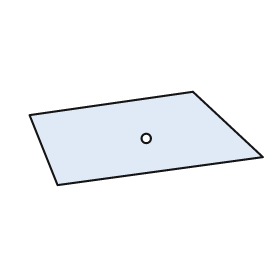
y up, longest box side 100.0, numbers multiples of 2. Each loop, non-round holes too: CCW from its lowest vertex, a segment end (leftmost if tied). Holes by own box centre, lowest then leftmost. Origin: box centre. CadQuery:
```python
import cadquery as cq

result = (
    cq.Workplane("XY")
    .moveTo(-38.0, -20.0)
    .lineTo(50.0, -8.0)
    .lineTo(20.0, 20.0)
    .lineTo(-50.0, 10.0)
    .close()
    .moveTo(0.0, 0.0)
    .circle(2.0)
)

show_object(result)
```